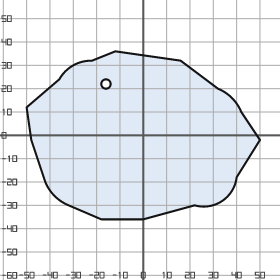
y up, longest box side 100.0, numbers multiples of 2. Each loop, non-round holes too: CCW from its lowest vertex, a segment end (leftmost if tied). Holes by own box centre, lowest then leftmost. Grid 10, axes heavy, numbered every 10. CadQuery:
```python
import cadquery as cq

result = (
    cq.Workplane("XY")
    .moveTo(-18.0, -36.0)
    .lineTo(0.0, -36.0)
    .lineTo(22.0, -30.0)
    .threePointArc((34.0, -28.0), (40.0, -18.0))
    .lineTo(50.0, -2.0)
    .lineTo(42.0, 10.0)
    .threePointArc((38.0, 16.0), (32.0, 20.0))
    .lineTo(16.0, 32.0)
    .lineTo(-12.0, 36.0)
    .lineTo(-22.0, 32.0)
    .threePointArc((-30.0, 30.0), (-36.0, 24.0))
    .lineTo(-50.0, 12.0)
    .lineTo(-48.0, -2.0)
    .lineTo(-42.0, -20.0)
    .threePointArc((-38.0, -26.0), (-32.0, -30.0))
    .close()
    .moveTo(-16.0, 22.0)
    .circle(2.0)
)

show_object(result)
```